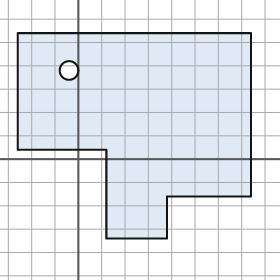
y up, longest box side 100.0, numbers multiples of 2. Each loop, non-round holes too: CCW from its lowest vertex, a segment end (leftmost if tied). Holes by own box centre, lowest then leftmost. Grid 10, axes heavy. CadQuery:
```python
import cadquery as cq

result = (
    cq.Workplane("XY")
    .moveTo(12.0, -34.0)
    .lineTo(38.0, -34.0)
    .lineTo(38.0, -16.0)
    .lineTo(74.0, -16.0)
    .lineTo(74.0, 54.0)
    .lineTo(-26.0, 54.0)
    .lineTo(-26.0, 4.0)
    .lineTo(12.0, 4.0)
    .close()
    .moveTo(-4.0, 38.0)
    .circle(4.0)
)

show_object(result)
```